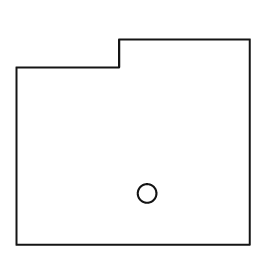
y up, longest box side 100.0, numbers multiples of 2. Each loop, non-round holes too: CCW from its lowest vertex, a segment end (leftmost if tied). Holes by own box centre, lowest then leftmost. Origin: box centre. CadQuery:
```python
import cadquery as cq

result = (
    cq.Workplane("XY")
    .moveTo(-50.0, -44.0)
    .lineTo(50.0, -44.0)
    .lineTo(50.0, 44.0)
    .lineTo(-6.0, 44.0)
    .lineTo(-6.0, 32.0)
    .lineTo(-50.0, 32.0)
    .close()
    .moveTo(6.0, -22.0)
    .circle(4.0)
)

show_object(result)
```